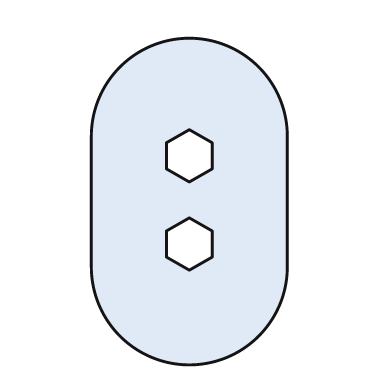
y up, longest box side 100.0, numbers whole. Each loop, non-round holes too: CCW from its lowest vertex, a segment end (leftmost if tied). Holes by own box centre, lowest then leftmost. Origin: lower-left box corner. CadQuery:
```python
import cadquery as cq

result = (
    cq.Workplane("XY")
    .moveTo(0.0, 30.0)
    .threePointArc((30.0, 0.0), (60.0, 30.0))
    .lineTo(60.0, 70.0)
    .threePointArc((30.0, 100.0), (0.0, 70.0))
    .close()
    .moveTo(30.0, 29.0)
    .lineTo(37.0, 33.0)
    .lineTo(37.0, 41.0)
    .lineTo(30.0, 45.0)
    .lineTo(23.0, 41.0)
    .lineTo(23.0, 33.0)
    .close()
    .moveTo(30.0, 56.0)
    .lineTo(37.0, 60.0)
    .lineTo(37.0, 68.0)
    .lineTo(30.0, 72.0)
    .lineTo(23.0, 68.0)
    .lineTo(23.0, 60.0)
    .close()
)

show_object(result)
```